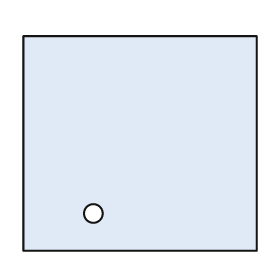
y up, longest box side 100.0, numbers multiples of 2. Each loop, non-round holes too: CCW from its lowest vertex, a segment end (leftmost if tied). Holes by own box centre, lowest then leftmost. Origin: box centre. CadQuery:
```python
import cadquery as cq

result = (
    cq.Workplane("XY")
    .moveTo(-50.0, -46.0)
    .lineTo(50.0, -46.0)
    .lineTo(50.0, 46.0)
    .lineTo(-50.0, 46.0)
    .close()
    .moveTo(-20.0, -30.0)
    .circle(4.0)
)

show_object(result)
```